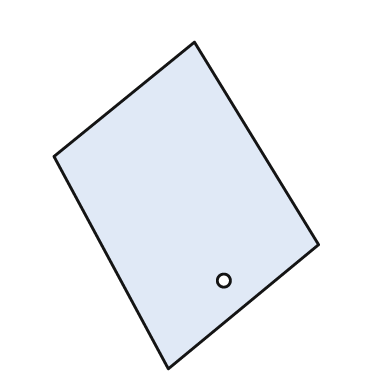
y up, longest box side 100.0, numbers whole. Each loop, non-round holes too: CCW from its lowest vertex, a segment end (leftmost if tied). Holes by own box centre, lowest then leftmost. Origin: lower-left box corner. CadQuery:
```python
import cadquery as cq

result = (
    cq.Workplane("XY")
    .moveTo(35.0, 0.0)
    .lineTo(81.0, 38.0)
    .lineTo(43.0, 100.0)
    .lineTo(0.0, 65.0)
    .close()
    .moveTo(52.0, 27.0)
    .circle(2.0)
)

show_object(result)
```